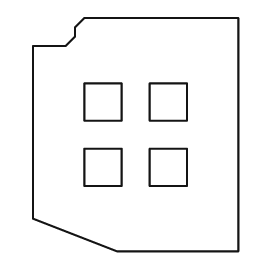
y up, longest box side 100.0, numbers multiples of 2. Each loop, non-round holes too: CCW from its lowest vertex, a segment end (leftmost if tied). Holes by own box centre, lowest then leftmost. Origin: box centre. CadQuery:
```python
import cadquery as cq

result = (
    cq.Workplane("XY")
    .moveTo(-8.0, -50.0)
    .lineTo(44.0, -50.0)
    .lineTo(44.0, 50.0)
    .lineTo(-22.0, 50.0)
    .lineTo(-26.0, 46.0)
    .lineTo(-26.0, 42.0)
    .lineTo(-30.0, 38.0)
    .lineTo(-44.0, 38.0)
    .lineTo(-44.0, -36.0)
    .close()
    .moveTo(-22.0, -22.0)
    .lineTo(-6.0, -22.0)
    .lineTo(-6.0, -6.0)
    .lineTo(-22.0, -6.0)
    .close()
    .moveTo(6.0, -22.0)
    .lineTo(22.0, -22.0)
    .lineTo(22.0, -6.0)
    .lineTo(6.0, -6.0)
    .close()
    .moveTo(-22.0, 6.0)
    .lineTo(-6.0, 6.0)
    .lineTo(-6.0, 22.0)
    .lineTo(-22.0, 22.0)
    .close()
    .moveTo(6.0, 6.0)
    .lineTo(22.0, 6.0)
    .lineTo(22.0, 22.0)
    .lineTo(6.0, 22.0)
    .close()
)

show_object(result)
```